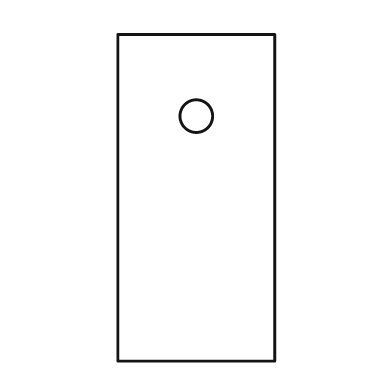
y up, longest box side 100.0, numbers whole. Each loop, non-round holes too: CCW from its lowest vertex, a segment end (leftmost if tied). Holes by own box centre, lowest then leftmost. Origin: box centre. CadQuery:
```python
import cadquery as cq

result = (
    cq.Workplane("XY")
    .moveTo(-24.0, -50.0)
    .lineTo(24.0, -50.0)
    .lineTo(24.0, 50.0)
    .lineTo(-24.0, 50.0)
    .close()
    .moveTo(0.0, 25.0)
    .circle(5.0)
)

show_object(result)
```